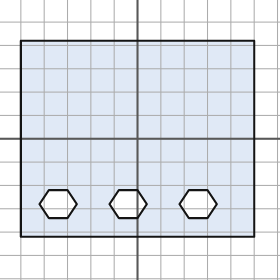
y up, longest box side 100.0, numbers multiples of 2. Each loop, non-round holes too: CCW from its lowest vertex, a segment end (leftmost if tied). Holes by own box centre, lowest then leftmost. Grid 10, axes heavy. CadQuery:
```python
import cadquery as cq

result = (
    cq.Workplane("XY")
    .moveTo(-50.0, -42.0)
    .lineTo(50.0, -42.0)
    .lineTo(50.0, 42.0)
    .lineTo(-50.0, 42.0)
    .close()
    .moveTo(-38.0, -34.0)
    .lineTo(-30.0, -34.0)
    .lineTo(-26.0, -28.0)
    .lineTo(-30.0, -22.0)
    .lineTo(-38.0, -22.0)
    .lineTo(-42.0, -28.0)
    .close()
    .moveTo(-8.0, -34.0)
    .lineTo(0.0, -34.0)
    .lineTo(4.0, -28.0)
    .lineTo(0.0, -22.0)
    .lineTo(-8.0, -22.0)
    .lineTo(-12.0, -28.0)
    .close()
    .moveTo(22.0, -34.0)
    .lineTo(30.0, -34.0)
    .lineTo(34.0, -28.0)
    .lineTo(30.0, -22.0)
    .lineTo(22.0, -22.0)
    .lineTo(18.0, -28.0)
    .close()
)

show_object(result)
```